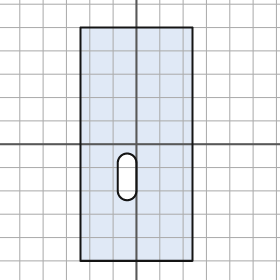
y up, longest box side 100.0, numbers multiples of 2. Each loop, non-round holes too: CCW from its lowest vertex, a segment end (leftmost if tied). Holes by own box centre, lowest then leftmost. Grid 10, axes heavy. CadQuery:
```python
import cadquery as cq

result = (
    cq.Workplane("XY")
    .moveTo(-24.0, -50.0)
    .lineTo(24.0, -50.0)
    .lineTo(24.0, 50.0)
    .lineTo(-24.0, 50.0)
    .close()
    .moveTo(-8.0, -20.0)
    .threePointArc((-4.0, -24.0), (0.0, -20.0))
    .lineTo(0.0, -8.0)
    .threePointArc((-4.0, -4.0), (-8.0, -8.0))
    .close()
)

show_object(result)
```